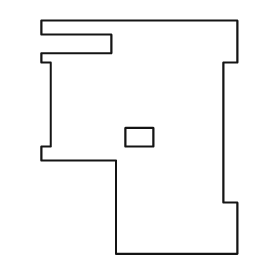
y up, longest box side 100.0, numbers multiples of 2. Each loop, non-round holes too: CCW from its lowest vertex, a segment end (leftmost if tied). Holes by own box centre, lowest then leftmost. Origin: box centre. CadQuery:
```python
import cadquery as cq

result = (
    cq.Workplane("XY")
    .moveTo(-10.0, -50.0)
    .lineTo(42.0, -50.0)
    .lineTo(42.0, -28.0)
    .lineTo(36.0, -28.0)
    .lineTo(36.0, 32.0)
    .lineTo(42.0, 32.0)
    .lineTo(42.0, 50.0)
    .lineTo(-42.0, 50.0)
    .lineTo(-42.0, 44.0)
    .lineTo(-12.0, 44.0)
    .lineTo(-12.0, 36.0)
    .lineTo(-42.0, 36.0)
    .lineTo(-42.0, 32.0)
    .lineTo(-38.0, 32.0)
    .lineTo(-38.0, -4.0)
    .lineTo(-42.0, -4.0)
    .lineTo(-42.0, -10.0)
    .lineTo(-10.0, -10.0)
    .close()
    .moveTo(-6.0, -4.0)
    .lineTo(6.0, -4.0)
    .lineTo(6.0, 4.0)
    .lineTo(-6.0, 4.0)
    .close()
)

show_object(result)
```